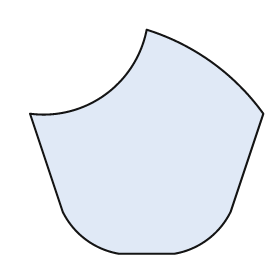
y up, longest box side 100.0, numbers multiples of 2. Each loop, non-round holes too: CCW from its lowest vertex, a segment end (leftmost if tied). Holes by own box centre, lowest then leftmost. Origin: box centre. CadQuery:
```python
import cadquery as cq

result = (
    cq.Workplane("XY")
    .moveTo(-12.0, -48.0)
    .lineTo(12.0, -48.0)
    .threePointArc((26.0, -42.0), (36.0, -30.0))
    .lineTo(50.0, 12.0)
    .threePointArc((28.0, 34.0), (0.0, 48.0))
    .threePointArc((-18.0, 20.0), (-50.0, 12.0))
    .lineTo(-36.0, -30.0)
    .threePointArc((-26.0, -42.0), (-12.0, -48.0))
    .close()
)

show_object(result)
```